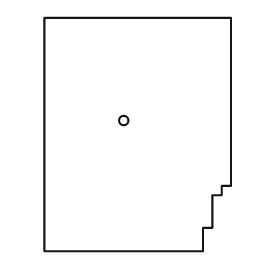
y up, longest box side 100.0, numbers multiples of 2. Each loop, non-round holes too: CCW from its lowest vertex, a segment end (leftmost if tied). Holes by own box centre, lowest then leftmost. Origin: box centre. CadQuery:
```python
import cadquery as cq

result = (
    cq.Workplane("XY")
    .moveTo(-40.0, -50.0)
    .lineTo(28.0, -50.0)
    .lineTo(28.0, -40.0)
    .lineTo(32.0, -40.0)
    .lineTo(32.0, -26.0)
    .lineTo(36.0, -26.0)
    .lineTo(36.0, -22.0)
    .lineTo(40.0, -22.0)
    .lineTo(40.0, 50.0)
    .lineTo(-40.0, 50.0)
    .close()
    .moveTo(-6.0, 6.0)
    .circle(2.0)
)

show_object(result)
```